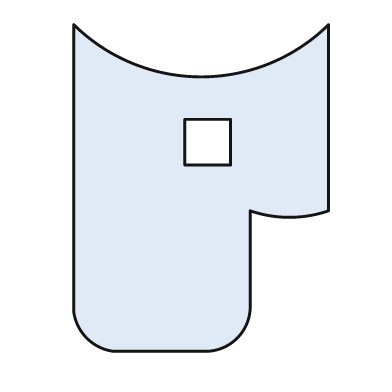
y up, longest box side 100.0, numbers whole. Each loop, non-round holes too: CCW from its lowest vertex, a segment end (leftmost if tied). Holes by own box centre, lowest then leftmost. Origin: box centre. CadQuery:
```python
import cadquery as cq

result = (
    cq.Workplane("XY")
    .moveTo(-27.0, -50.0)
    .lineTo(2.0, -50.0)
    .threePointArc((11.0, -46.0), (15.0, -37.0))
    .lineTo(15.0, -7.0)
    .threePointArc((27.0, -9.0), (39.0, -7.0))
    .lineTo(39.0, 50.0)
    .threePointArc((0.0, 34.0), (-39.0, 50.0))
    .lineTo(-39.0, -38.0)
    .threePointArc((-35.0, -46.0), (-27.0, -50.0))
    .close()
    .moveTo(-5.0, 7.0)
    .lineTo(9.0, 7.0)
    .lineTo(9.0, 21.0)
    .lineTo(-5.0, 21.0)
    .close()
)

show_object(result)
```